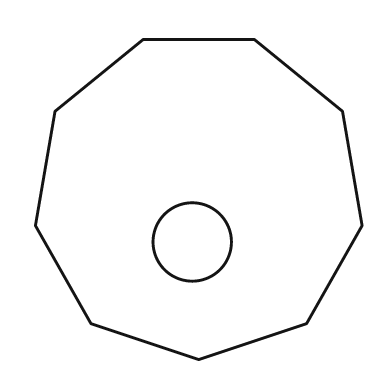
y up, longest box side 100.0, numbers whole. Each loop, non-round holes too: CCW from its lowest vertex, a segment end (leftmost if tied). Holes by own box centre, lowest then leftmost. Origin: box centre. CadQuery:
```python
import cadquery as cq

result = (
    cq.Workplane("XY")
    .moveTo(0.0, -49.0)
    .lineTo(33.0, -38.0)
    .lineTo(50.0, -8.0)
    .lineTo(44.0, 27.0)
    .lineTo(17.0, 49.0)
    .lineTo(-17.0, 49.0)
    .lineTo(-44.0, 27.0)
    .lineTo(-50.0, -8.0)
    .lineTo(-33.0, -38.0)
    .close()
    .moveTo(-2.0, -13.0)
    .circle(12.0)
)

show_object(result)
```